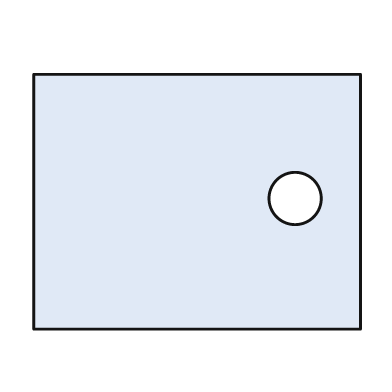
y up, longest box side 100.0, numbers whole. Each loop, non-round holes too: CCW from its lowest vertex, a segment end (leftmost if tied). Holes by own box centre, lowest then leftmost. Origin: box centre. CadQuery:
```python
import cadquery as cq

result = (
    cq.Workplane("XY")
    .moveTo(-50.0, -39.0)
    .lineTo(50.0, -39.0)
    .lineTo(50.0, 39.0)
    .lineTo(-50.0, 39.0)
    .close()
    .moveTo(30.0, 1.0)
    .circle(8.0)
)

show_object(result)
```